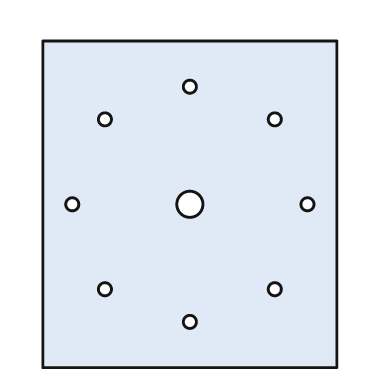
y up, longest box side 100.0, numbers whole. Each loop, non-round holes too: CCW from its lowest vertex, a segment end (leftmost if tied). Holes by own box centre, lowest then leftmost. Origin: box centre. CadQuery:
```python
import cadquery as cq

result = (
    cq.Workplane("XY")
    .moveTo(-45.0, -50.0)
    .lineTo(45.0, -50.0)
    .lineTo(45.0, 50.0)
    .lineTo(-45.0, 50.0)
    .close()
    .moveTo(0.0, -36.0)
    .circle(2.0)
    .moveTo(-26.0, -26.0)
    .circle(2.0)
    .moveTo(26.0, -26.0)
    .circle(2.0)
    .moveTo(-36.0, 0.0)
    .circle(2.0)
    .moveTo(0.0, 0.0)
    .circle(4.0)
    .moveTo(36.0, 0.0)
    .circle(2.0)
    .moveTo(-26.0, 26.0)
    .circle(2.0)
    .moveTo(26.0, 26.0)
    .circle(2.0)
    .moveTo(0.0, 36.0)
    .circle(2.0)
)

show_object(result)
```